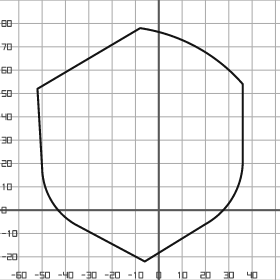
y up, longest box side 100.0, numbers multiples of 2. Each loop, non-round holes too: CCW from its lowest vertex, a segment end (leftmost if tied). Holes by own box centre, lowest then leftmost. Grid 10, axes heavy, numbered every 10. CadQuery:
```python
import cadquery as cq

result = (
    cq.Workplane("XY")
    .moveTo(-6.0, -22.0)
    .lineTo(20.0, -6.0)
    .threePointArc((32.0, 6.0), (36.0, 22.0))
    .lineTo(36.0, 54.0)
    .threePointArc((16.0, 70.0), (-8.0, 78.0))
    .lineTo(-52.0, 52.0)
    .lineTo(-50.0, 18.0)
    .threePointArc((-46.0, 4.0), (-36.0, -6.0))
    .close()
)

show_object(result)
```